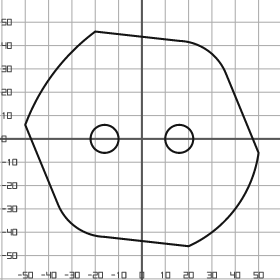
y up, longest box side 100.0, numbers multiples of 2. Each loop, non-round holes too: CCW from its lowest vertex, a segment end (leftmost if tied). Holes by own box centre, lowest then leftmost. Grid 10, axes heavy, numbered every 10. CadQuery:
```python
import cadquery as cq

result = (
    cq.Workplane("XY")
    .moveTo(20.0, -46.0)
    .threePointArc((40.0, -30.0), (50.0, -6.0))
    .lineTo(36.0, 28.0)
    .threePointArc((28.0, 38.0), (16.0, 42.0))
    .lineTo(-20.0, 46.0)
    .threePointArc((-38.0, 28.0), (-50.0, 6.0))
    .lineTo(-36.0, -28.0)
    .threePointArc((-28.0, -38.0), (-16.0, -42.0))
    .close()
    .moveTo(-16.0, 0.0)
    .circle(6.0)
    .moveTo(16.0, 0.0)
    .circle(6.0)
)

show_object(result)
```